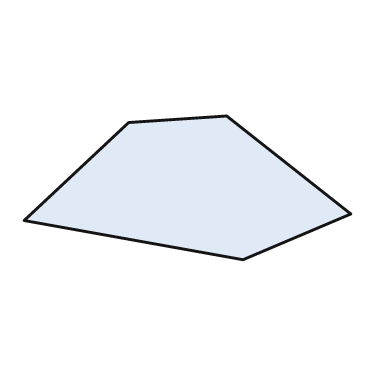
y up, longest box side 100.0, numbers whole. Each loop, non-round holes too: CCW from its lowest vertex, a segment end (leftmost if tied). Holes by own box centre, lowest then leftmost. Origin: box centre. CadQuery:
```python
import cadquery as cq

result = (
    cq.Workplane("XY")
    .moveTo(17.0, -22.0)
    .lineTo(50.0, -8.0)
    .lineTo(12.0, 22.0)
    .lineTo(-18.0, 20.0)
    .lineTo(-50.0, -10.0)
    .close()
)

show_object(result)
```